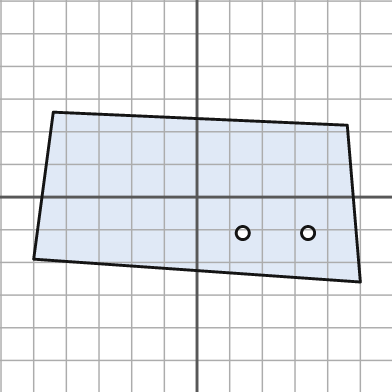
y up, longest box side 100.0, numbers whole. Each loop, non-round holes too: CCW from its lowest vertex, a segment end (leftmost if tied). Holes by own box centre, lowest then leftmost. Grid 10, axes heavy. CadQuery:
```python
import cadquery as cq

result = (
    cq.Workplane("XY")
    .moveTo(50.0, -26.0)
    .lineTo(46.0, 22.0)
    .lineTo(-44.0, 26.0)
    .lineTo(-50.0, -19.0)
    .close()
    .moveTo(14.0, -11.0)
    .circle(2.0)
    .moveTo(34.0, -11.0)
    .circle(2.0)
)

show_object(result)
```